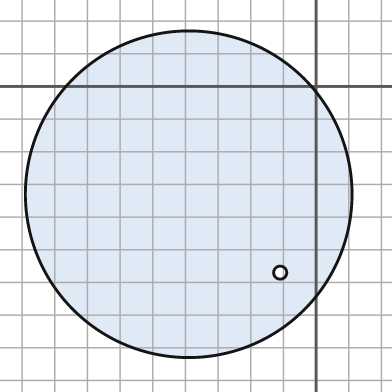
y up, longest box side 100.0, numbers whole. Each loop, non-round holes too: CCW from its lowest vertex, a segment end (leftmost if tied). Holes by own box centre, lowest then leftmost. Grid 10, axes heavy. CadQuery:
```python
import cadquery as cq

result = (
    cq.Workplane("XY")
    .moveTo(-39.0, -33.0)
    .circle(50.0)
    .moveTo(-11.0, -57.0)
    .circle(2.0)
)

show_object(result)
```